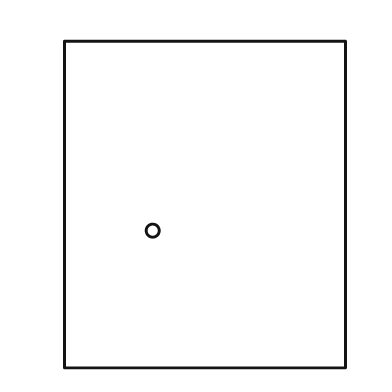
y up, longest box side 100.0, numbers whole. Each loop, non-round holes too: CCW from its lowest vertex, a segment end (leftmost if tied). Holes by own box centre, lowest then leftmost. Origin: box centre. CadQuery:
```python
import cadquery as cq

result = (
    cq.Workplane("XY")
    .moveTo(-43.0, -50.0)
    .lineTo(43.0, -50.0)
    .lineTo(43.0, 50.0)
    .lineTo(-43.0, 50.0)
    .close()
    .moveTo(-16.0, -8.0)
    .circle(2.0)
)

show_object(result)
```